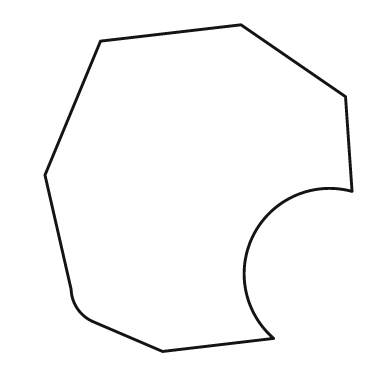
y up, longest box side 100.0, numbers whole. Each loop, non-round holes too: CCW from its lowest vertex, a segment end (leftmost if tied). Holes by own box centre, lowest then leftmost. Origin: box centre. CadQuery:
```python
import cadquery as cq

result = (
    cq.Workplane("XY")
    .moveTo(-11.0, -50.0)
    .lineTo(23.0, -46.0)
    .threePointArc((17.0, -14.0), (47.0, -1.0))
    .lineTo(45.0, 28.0)
    .lineTo(13.0, 50.0)
    .lineTo(-30.0, 45.0)
    .lineTo(-47.0, 4.0)
    .lineTo(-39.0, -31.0)
    .threePointArc((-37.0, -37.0), (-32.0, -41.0))
    .close()
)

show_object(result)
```